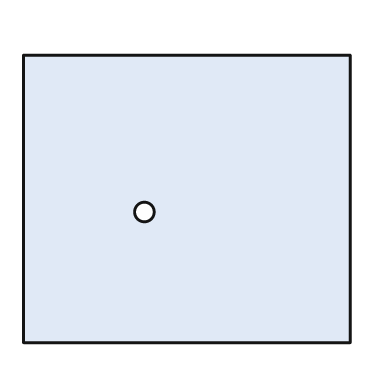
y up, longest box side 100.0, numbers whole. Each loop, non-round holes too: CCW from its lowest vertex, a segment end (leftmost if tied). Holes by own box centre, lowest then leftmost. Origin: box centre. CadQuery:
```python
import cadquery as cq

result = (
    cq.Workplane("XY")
    .moveTo(-50.0, -44.0)
    .lineTo(50.0, -44.0)
    .lineTo(50.0, 44.0)
    .lineTo(-50.0, 44.0)
    .close()
    .moveTo(-13.0, -4.0)
    .circle(3.0)
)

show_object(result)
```